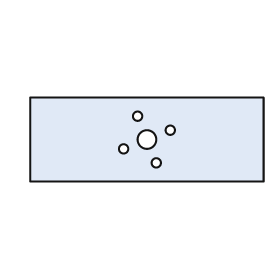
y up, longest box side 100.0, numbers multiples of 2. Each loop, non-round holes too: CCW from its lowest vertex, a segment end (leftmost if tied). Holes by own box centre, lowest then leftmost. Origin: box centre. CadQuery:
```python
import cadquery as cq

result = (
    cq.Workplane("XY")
    .moveTo(-50.0, -18.0)
    .lineTo(50.0, -18.0)
    .lineTo(50.0, 18.0)
    .lineTo(-50.0, 18.0)
    .close()
    .moveTo(4.0, -10.0)
    .circle(2.0)
    .moveTo(-10.0, -4.0)
    .circle(2.0)
    .moveTo(0.0, 0.0)
    .circle(4.0)
    .moveTo(10.0, 4.0)
    .circle(2.0)
    .moveTo(-4.0, 10.0)
    .circle(2.0)
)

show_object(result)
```